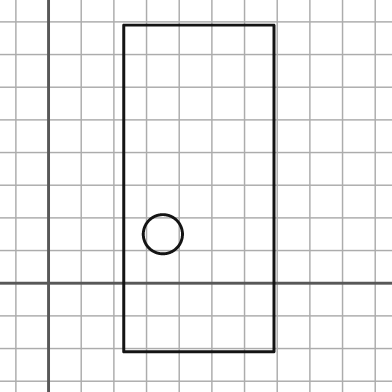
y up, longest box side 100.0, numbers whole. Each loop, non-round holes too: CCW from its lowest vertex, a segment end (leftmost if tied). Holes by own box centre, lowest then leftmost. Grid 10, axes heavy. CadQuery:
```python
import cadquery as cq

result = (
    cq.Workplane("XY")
    .moveTo(23.0, -21.0)
    .lineTo(69.0, -21.0)
    .lineTo(69.0, 79.0)
    .lineTo(23.0, 79.0)
    .close()
    .moveTo(35.0, 15.0)
    .circle(6.0)
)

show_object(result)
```